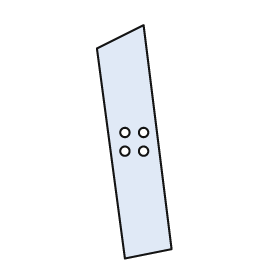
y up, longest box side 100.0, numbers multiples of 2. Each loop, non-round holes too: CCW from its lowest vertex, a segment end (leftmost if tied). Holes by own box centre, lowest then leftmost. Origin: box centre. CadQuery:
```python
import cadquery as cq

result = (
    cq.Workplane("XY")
    .moveTo(-4.0, -50.0)
    .lineTo(16.0, -46.0)
    .lineTo(4.0, 50.0)
    .lineTo(-16.0, 40.0)
    .close()
    .moveTo(-4.0, -4.0)
    .circle(2.0)
    .moveTo(4.0, -4.0)
    .circle(2.0)
    .moveTo(-4.0, 4.0)
    .circle(2.0)
    .moveTo(4.0, 4.0)
    .circle(2.0)
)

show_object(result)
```